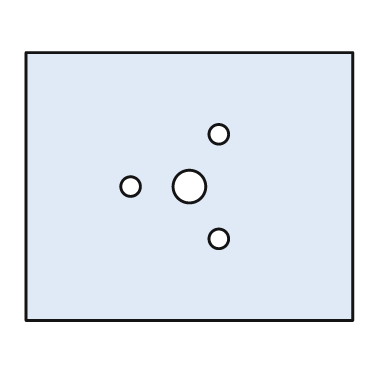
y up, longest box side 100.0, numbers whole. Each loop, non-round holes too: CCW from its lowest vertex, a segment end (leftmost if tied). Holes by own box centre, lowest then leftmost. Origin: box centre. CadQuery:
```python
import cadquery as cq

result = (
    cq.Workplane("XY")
    .moveTo(-50.0, -41.0)
    .lineTo(50.0, -41.0)
    .lineTo(50.0, 41.0)
    .lineTo(-50.0, 41.0)
    .close()
    .moveTo(9.0, -16.0)
    .circle(3.0)
    .moveTo(-18.0, 0.0)
    .circle(3.0)
    .moveTo(0.0, 0.0)
    .circle(5.0)
    .moveTo(9.0, 16.0)
    .circle(3.0)
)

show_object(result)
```